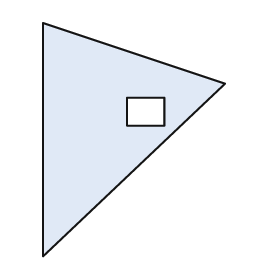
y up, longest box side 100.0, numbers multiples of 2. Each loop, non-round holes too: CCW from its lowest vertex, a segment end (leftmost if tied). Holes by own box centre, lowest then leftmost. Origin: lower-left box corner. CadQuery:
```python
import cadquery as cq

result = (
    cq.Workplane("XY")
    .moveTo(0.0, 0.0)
    .lineTo(78.0, 74.0)
    .lineTo(0.0, 100.0)
    .close()
    .moveTo(36.0, 56.0)
    .lineTo(52.0, 56.0)
    .lineTo(52.0, 68.0)
    .lineTo(36.0, 68.0)
    .close()
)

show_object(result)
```